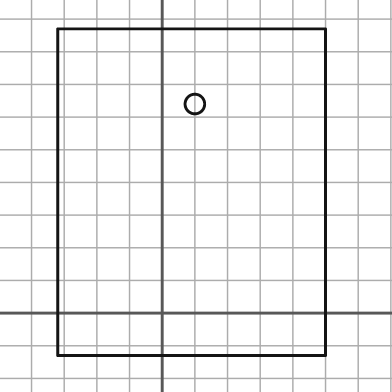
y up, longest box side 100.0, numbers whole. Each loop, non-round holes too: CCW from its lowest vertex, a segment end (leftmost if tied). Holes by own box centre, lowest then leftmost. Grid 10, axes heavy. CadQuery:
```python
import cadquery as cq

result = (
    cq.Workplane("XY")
    .moveTo(-32.0, -13.0)
    .lineTo(50.0, -13.0)
    .lineTo(50.0, 87.0)
    .lineTo(-32.0, 87.0)
    .close()
    .moveTo(10.0, 64.0)
    .circle(3.0)
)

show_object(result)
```